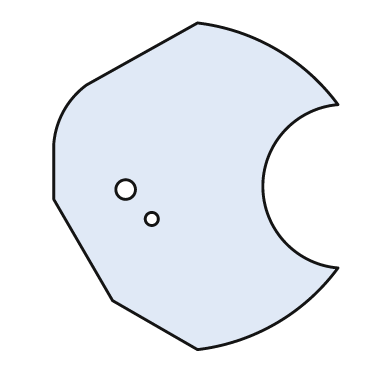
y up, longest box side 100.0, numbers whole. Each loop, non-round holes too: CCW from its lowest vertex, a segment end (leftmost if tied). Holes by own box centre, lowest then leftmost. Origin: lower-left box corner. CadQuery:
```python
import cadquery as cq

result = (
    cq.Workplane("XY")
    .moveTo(44.0, 0.0)
    .threePointArc((68.0, 8.0), (87.0, 25.0))
    .threePointArc((64.0, 50.0), (87.0, 75.0))
    .threePointArc((68.0, 92.0), (44.0, 100.0))
    .lineTo(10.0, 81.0)
    .threePointArc((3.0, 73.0), (0.0, 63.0))
    .lineTo(0.0, 46.0)
    .lineTo(18.0, 15.0)
    .close()
    .moveTo(30.0, 40.0)
    .circle(2.0)
    .moveTo(22.0, 49.0)
    .circle(3.0)
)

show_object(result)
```